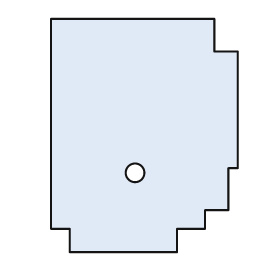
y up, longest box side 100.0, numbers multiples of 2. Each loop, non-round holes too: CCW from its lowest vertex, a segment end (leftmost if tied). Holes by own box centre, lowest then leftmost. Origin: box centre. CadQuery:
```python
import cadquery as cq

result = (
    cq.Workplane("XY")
    .moveTo(-32.0, -50.0)
    .lineTo(14.0, -50.0)
    .lineTo(14.0, -40.0)
    .lineTo(26.0, -40.0)
    .lineTo(26.0, -32.0)
    .lineTo(36.0, -32.0)
    .lineTo(36.0, -14.0)
    .lineTo(40.0, -14.0)
    .lineTo(40.0, 36.0)
    .lineTo(30.0, 36.0)
    .lineTo(30.0, 50.0)
    .lineTo(-40.0, 50.0)
    .lineTo(-40.0, -40.0)
    .lineTo(-32.0, -40.0)
    .close()
    .moveTo(-4.0, -16.0)
    .circle(4.0)
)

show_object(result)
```